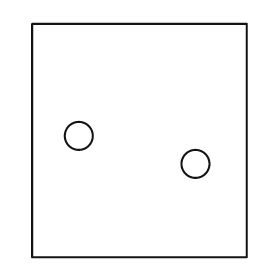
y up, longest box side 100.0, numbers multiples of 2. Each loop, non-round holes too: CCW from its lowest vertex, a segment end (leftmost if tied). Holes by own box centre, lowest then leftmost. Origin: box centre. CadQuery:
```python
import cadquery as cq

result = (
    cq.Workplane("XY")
    .moveTo(-46.0, -50.0)
    .lineTo(46.0, -50.0)
    .lineTo(46.0, 50.0)
    .lineTo(-46.0, 50.0)
    .close()
    .moveTo(24.0, -10.0)
    .circle(6.0)
    .moveTo(-26.0, 2.0)
    .circle(6.0)
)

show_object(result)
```